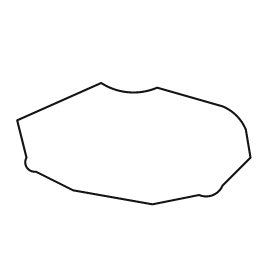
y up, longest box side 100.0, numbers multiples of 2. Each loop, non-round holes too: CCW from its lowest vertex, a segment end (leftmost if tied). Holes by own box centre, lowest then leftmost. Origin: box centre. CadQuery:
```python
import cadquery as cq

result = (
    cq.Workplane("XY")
    .moveTo(8.0, -26.0)
    .lineTo(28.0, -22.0)
    .threePointArc((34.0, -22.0), (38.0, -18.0))
    .lineTo(50.0, -6.0)
    .lineTo(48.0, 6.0)
    .threePointArc((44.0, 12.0), (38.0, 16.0))
    .lineTo(10.0, 24.0)
    .threePointArc((-2.0, 22.0), (-14.0, 26.0))
    .lineTo(-50.0, 10.0)
    .lineTo(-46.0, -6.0)
    .threePointArc((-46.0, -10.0), (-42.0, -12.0))
    .lineTo(-26.0, -20.0)
    .close()
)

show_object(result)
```